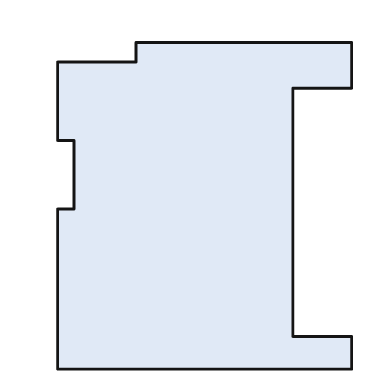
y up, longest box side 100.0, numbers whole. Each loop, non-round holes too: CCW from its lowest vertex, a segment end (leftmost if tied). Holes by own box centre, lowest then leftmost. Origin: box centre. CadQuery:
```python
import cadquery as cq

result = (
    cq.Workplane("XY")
    .moveTo(-45.0, -50.0)
    .lineTo(45.0, -50.0)
    .lineTo(45.0, -40.0)
    .lineTo(27.0, -40.0)
    .lineTo(27.0, 36.0)
    .lineTo(45.0, 36.0)
    .lineTo(45.0, 50.0)
    .lineTo(-21.0, 50.0)
    .lineTo(-21.0, 44.0)
    .lineTo(-45.0, 44.0)
    .lineTo(-45.0, 20.0)
    .lineTo(-40.0, 20.0)
    .lineTo(-40.0, -1.0)
    .lineTo(-45.0, -1.0)
    .close()
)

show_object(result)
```